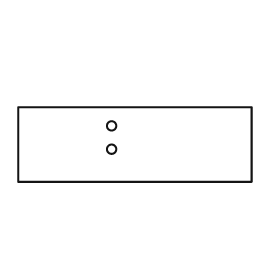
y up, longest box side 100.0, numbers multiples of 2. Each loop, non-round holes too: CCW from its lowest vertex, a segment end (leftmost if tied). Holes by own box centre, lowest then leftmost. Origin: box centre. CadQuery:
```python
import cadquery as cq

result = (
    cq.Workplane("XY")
    .moveTo(-50.0, -16.0)
    .lineTo(50.0, -16.0)
    .lineTo(50.0, 16.0)
    .lineTo(-50.0, 16.0)
    .close()
    .moveTo(-10.0, -2.0)
    .circle(2.0)
    .moveTo(-10.0, 8.0)
    .circle(2.0)
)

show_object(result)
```